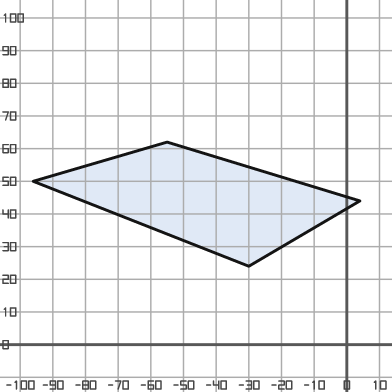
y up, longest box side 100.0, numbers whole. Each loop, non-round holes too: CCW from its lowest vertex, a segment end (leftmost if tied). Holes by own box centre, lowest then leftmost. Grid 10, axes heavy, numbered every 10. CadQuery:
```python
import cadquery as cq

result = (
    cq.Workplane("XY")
    .moveTo(-30.0, 24.0)
    .lineTo(4.0, 44.0)
    .lineTo(-55.0, 62.0)
    .lineTo(-96.0, 50.0)
    .close()
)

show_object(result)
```